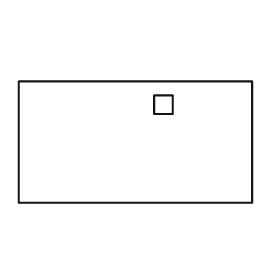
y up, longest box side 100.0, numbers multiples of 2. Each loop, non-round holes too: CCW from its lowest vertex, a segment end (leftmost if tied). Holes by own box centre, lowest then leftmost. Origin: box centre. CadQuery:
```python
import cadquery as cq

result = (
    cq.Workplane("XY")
    .moveTo(-50.0, -26.0)
    .lineTo(50.0, -26.0)
    .lineTo(50.0, 26.0)
    .lineTo(-50.0, 26.0)
    .close()
    .moveTo(8.0, 12.0)
    .lineTo(16.0, 12.0)
    .lineTo(16.0, 20.0)
    .lineTo(8.0, 20.0)
    .close()
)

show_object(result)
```